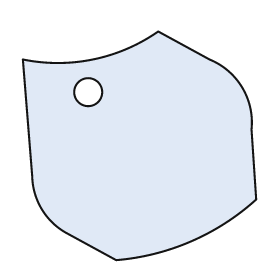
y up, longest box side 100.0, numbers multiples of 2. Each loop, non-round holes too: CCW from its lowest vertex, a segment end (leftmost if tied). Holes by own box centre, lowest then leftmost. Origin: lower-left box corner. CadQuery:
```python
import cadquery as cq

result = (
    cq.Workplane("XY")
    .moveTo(40.0, 0.0)
    .threePointArc((72.0, 8.0), (100.0, 26.0))
    .lineTo(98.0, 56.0)
    .threePointArc((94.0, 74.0), (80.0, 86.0))
    .lineTo(58.0, 98.0)
    .threePointArc((30.0, 86.0), (0.0, 86.0))
    .lineTo(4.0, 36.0)
    .threePointArc((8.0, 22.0), (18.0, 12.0))
    .close()
    .moveTo(28.0, 72.0)
    .circle(6.0)
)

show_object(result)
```